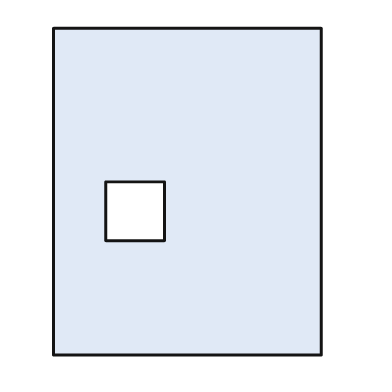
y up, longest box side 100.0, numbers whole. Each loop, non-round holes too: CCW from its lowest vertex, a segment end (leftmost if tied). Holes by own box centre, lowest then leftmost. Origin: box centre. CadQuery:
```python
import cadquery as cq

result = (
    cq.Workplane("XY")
    .moveTo(-41.0, -50.0)
    .lineTo(41.0, -50.0)
    .lineTo(41.0, 50.0)
    .lineTo(-41.0, 50.0)
    .close()
    .moveTo(-25.0, -15.0)
    .lineTo(-7.0, -15.0)
    .lineTo(-7.0, 3.0)
    .lineTo(-25.0, 3.0)
    .close()
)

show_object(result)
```